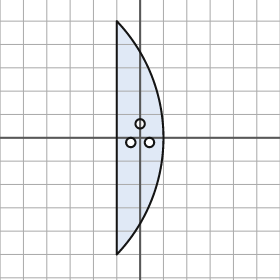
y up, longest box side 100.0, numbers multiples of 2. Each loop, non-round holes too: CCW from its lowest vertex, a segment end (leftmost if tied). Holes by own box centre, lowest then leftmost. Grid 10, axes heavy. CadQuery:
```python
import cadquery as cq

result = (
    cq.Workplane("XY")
    .moveTo(-10.0, -50.0)
    .threePointArc((10.0, 0.0), (-10.0, 50.0))
    .close()
    .moveTo(-4.0, -2.0)
    .circle(2.0)
    .moveTo(4.0, -2.0)
    .circle(2.0)
    .moveTo(0.0, 6.0)
    .circle(2.0)
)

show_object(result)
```